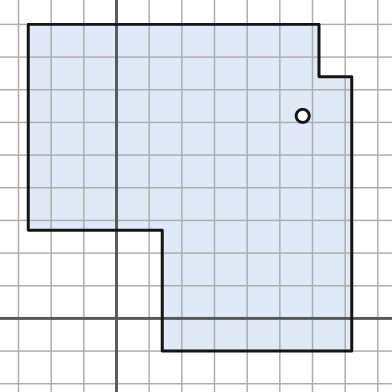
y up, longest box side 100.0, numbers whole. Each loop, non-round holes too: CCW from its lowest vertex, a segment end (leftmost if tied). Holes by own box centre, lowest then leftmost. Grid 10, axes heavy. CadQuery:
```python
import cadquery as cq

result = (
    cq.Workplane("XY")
    .moveTo(14.0, -10.0)
    .lineTo(72.0, -10.0)
    .lineTo(72.0, 74.0)
    .lineTo(62.0, 74.0)
    .lineTo(62.0, 90.0)
    .lineTo(-27.0, 90.0)
    .lineTo(-27.0, 27.0)
    .lineTo(14.0, 27.0)
    .close()
    .moveTo(57.0, 62.0)
    .circle(2.0)
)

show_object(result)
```